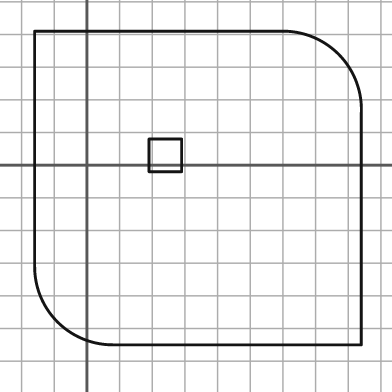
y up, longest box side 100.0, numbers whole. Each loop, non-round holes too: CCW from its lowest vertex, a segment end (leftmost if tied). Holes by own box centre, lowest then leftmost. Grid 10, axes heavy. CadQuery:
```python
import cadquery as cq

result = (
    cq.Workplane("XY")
    .moveTo(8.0, -55.0)
    .lineTo(84.0, -55.0)
    .lineTo(84.0, 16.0)
    .threePointArc((77.0, 34.0), (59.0, 41.0))
    .lineTo(-16.0, 41.0)
    .lineTo(-16.0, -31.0)
    .threePointArc((-9.0, -48.0), (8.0, -55.0))
    .close()
    .moveTo(19.0, -2.0)
    .lineTo(29.0, -2.0)
    .lineTo(29.0, 8.0)
    .lineTo(19.0, 8.0)
    .close()
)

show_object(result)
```